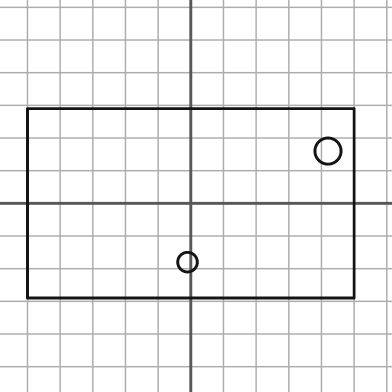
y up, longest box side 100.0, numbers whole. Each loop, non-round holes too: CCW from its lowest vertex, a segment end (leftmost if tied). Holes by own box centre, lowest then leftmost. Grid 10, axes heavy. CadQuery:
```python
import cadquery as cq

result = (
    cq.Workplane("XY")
    .moveTo(-50.0, -29.0)
    .lineTo(50.0, -29.0)
    .lineTo(50.0, 29.0)
    .lineTo(-50.0, 29.0)
    .close()
    .moveTo(-1.0, -18.0)
    .circle(3.0)
    .moveTo(42.0, 16.0)
    .circle(4.0)
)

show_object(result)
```